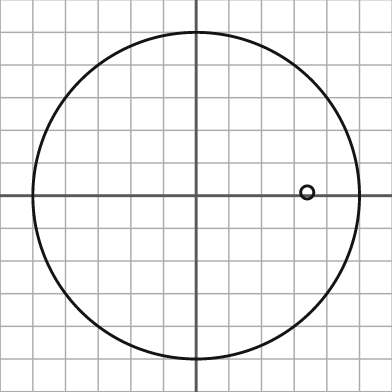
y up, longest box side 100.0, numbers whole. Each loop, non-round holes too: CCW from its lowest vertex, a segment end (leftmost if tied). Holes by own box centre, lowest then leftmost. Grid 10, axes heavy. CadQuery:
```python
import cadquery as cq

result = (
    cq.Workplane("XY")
    .moveTo(0.0, 0.0)
    .circle(50.0)
    .moveTo(34.0, 1.0)
    .circle(2.0)
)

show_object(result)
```